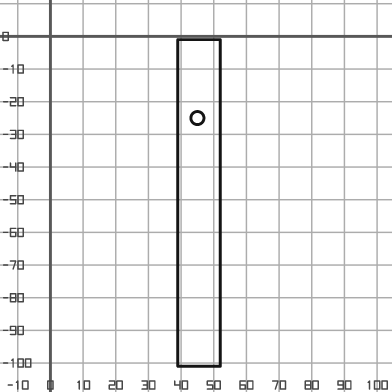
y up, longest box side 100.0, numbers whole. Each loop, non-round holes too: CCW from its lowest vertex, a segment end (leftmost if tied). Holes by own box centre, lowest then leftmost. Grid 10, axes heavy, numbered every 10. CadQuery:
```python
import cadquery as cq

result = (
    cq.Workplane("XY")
    .moveTo(39.0, -101.0)
    .lineTo(52.0, -101.0)
    .lineTo(52.0, -1.0)
    .lineTo(39.0, -1.0)
    .close()
    .moveTo(45.0, -25.0)
    .circle(2.0)
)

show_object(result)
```